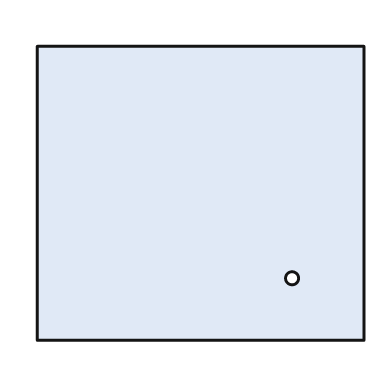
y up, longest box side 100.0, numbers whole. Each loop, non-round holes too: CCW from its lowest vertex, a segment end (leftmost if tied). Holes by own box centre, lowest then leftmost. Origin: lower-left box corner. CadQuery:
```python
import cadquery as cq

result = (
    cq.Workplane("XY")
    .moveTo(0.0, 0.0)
    .lineTo(100.0, 0.0)
    .lineTo(100.0, 90.0)
    .lineTo(0.0, 90.0)
    .close()
    .moveTo(78.0, 19.0)
    .circle(2.0)
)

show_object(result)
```